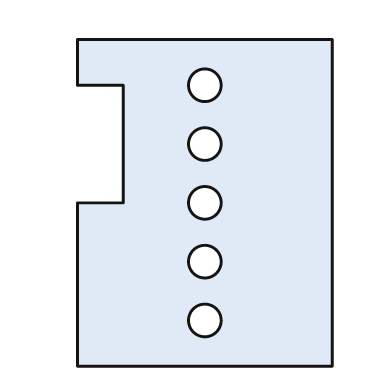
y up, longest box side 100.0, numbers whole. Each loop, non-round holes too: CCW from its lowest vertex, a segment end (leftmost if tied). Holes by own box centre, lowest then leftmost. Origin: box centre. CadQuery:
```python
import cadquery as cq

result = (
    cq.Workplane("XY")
    .moveTo(-39.0, -50.0)
    .lineTo(39.0, -50.0)
    .lineTo(39.0, 50.0)
    .lineTo(-39.0, 50.0)
    .lineTo(-39.0, 36.0)
    .lineTo(-25.0, 36.0)
    .lineTo(-25.0, 0.0)
    .lineTo(-39.0, 0.0)
    .close()
    .moveTo(0.0, -36.0)
    .circle(5.0)
    .moveTo(0.0, -18.0)
    .circle(5.0)
    .moveTo(0.0, 0.0)
    .circle(5.0)
    .moveTo(0.0, 18.0)
    .circle(5.0)
    .moveTo(0.0, 36.0)
    .circle(5.0)
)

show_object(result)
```